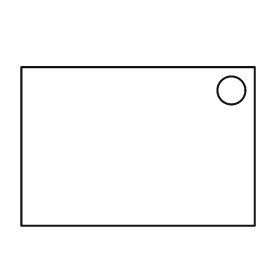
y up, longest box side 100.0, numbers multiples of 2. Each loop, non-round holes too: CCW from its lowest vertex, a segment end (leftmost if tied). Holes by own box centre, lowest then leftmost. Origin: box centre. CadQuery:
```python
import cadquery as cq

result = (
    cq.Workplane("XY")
    .moveTo(-50.0, -34.0)
    .lineTo(50.0, -34.0)
    .lineTo(50.0, 34.0)
    .lineTo(-50.0, 34.0)
    .close()
    .moveTo(40.0, 24.0)
    .circle(6.0)
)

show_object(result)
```